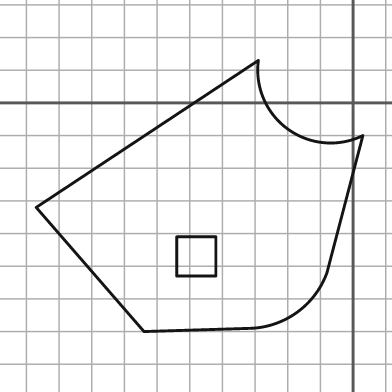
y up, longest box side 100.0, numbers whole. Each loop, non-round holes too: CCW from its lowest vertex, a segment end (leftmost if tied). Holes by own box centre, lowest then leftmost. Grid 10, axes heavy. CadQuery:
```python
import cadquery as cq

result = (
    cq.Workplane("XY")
    .moveTo(-64.0, -70.0)
    .lineTo(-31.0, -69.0)
    .threePointArc((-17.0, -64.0), (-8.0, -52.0))
    .lineTo(3.0, -10.0)
    .threePointArc((-20.0, -8.0), (-29.0, 13.0))
    .lineTo(-97.0, -32.0)
    .close()
    .moveTo(-54.0, -53.0)
    .lineTo(-42.0, -53.0)
    .lineTo(-42.0, -41.0)
    .lineTo(-54.0, -41.0)
    .close()
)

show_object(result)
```